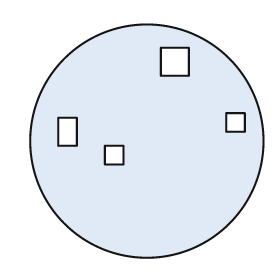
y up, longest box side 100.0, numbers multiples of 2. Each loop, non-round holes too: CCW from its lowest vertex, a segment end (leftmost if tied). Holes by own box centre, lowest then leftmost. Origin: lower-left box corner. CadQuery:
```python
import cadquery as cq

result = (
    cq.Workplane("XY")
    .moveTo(50.0, 50.0)
    .circle(50.0)
    .moveTo(32.0, 40.0)
    .lineTo(40.0, 40.0)
    .lineTo(40.0, 48.0)
    .lineTo(32.0, 48.0)
    .close()
    .moveTo(12.0, 48.0)
    .lineTo(20.0, 48.0)
    .lineTo(20.0, 60.0)
    .lineTo(12.0, 60.0)
    .close()
    .moveTo(84.0, 54.0)
    .lineTo(92.0, 54.0)
    .lineTo(92.0, 62.0)
    .lineTo(84.0, 62.0)
    .close()
    .moveTo(56.0, 78.0)
    .lineTo(68.0, 78.0)
    .lineTo(68.0, 90.0)
    .lineTo(56.0, 90.0)
    .close()
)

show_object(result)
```